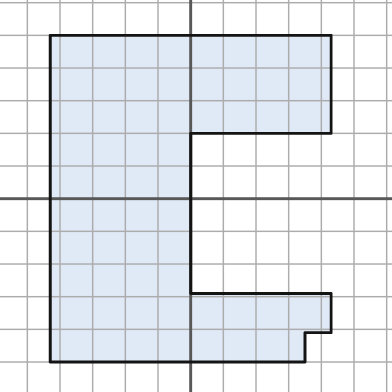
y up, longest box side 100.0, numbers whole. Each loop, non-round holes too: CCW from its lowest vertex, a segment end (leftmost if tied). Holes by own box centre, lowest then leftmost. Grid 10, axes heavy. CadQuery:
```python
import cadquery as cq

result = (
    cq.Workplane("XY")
    .moveTo(-43.0, -50.0)
    .lineTo(35.0, -50.0)
    .lineTo(35.0, -41.0)
    .lineTo(43.0, -41.0)
    .lineTo(43.0, -29.0)
    .lineTo(0.0, -29.0)
    .lineTo(0.0, 20.0)
    .lineTo(43.0, 20.0)
    .lineTo(43.0, 50.0)
    .lineTo(-43.0, 50.0)
    .close()
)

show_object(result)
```